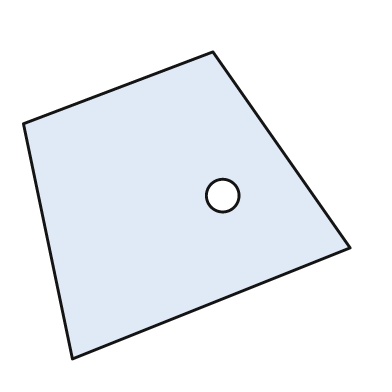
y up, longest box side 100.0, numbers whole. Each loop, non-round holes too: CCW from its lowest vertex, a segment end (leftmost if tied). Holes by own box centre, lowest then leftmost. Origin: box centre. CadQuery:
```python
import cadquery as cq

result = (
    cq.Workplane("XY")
    .moveTo(-35.0, -47.0)
    .lineTo(50.0, -13.0)
    .lineTo(8.0, 47.0)
    .lineTo(-50.0, 25.0)
    .close()
    .moveTo(11.0, 3.0)
    .circle(5.0)
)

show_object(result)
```